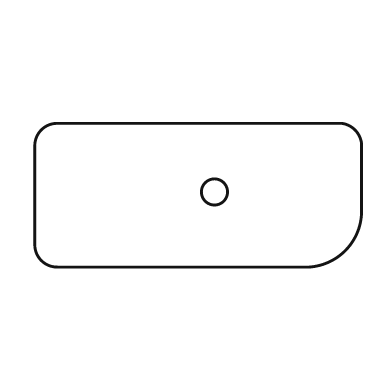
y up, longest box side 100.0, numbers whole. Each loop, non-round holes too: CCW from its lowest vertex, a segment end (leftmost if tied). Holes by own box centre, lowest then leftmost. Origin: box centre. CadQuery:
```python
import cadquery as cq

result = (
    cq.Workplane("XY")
    .moveTo(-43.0, -22.0)
    .lineTo(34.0, -22.0)
    .threePointArc((45.0, -17.0), (50.0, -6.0))
    .lineTo(50.0, 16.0)
    .threePointArc((48.0, 20.0), (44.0, 22.0))
    .lineTo(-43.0, 22.0)
    .threePointArc((-48.0, 20.0), (-50.0, 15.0))
    .lineTo(-50.0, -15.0)
    .threePointArc((-48.0, -20.0), (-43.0, -22.0))
    .close()
    .moveTo(5.0, 1.0)
    .circle(4.0)
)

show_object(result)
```